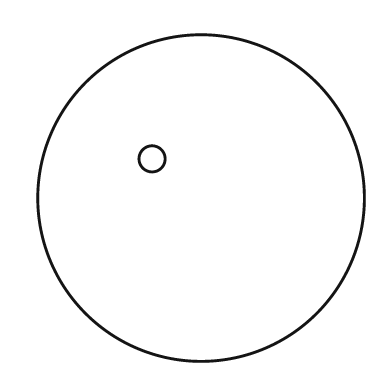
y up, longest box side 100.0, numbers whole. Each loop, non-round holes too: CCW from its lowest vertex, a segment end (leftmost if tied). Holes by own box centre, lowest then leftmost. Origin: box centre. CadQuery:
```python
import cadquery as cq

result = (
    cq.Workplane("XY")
    .moveTo(0.0, 0.0)
    .circle(50.0)
    .moveTo(-15.0, 12.0)
    .circle(4.0)
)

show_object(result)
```